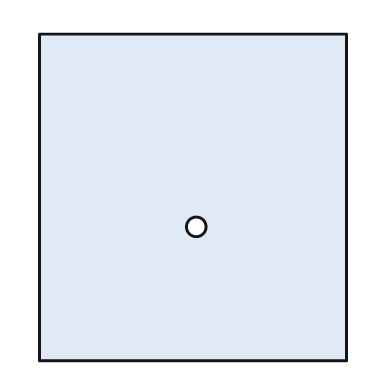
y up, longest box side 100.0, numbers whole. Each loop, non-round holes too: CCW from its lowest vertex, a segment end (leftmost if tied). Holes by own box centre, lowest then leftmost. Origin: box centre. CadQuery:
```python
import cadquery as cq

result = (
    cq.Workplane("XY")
    .moveTo(-47.0, -50.0)
    .lineTo(47.0, -50.0)
    .lineTo(47.0, 50.0)
    .lineTo(-47.0, 50.0)
    .close()
    .moveTo(1.0, -9.0)
    .circle(3.0)
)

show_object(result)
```